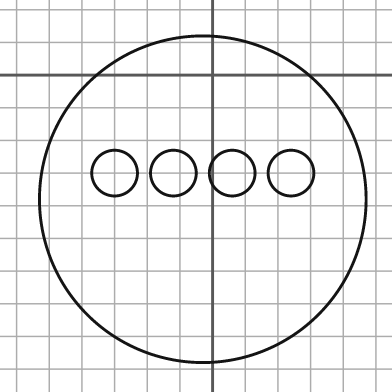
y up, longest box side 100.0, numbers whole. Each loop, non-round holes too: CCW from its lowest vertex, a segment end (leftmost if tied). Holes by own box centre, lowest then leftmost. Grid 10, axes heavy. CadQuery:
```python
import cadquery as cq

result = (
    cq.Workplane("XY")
    .moveTo(-3.0, -38.0)
    .circle(50.0)
    .moveTo(-30.0, -30.0)
    .circle(7.0)
    .moveTo(-12.0, -30.0)
    .circle(7.0)
    .moveTo(6.0, -30.0)
    .circle(7.0)
    .moveTo(24.0, -30.0)
    .circle(7.0)
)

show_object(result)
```